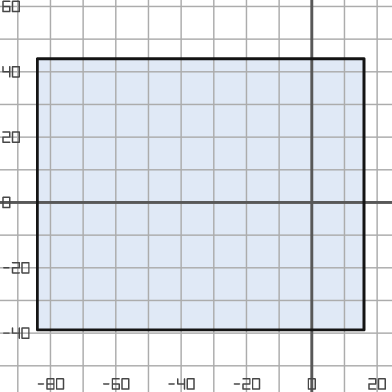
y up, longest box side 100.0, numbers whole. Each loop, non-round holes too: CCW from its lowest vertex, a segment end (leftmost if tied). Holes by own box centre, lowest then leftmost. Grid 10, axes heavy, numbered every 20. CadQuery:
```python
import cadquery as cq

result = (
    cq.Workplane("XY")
    .moveTo(-84.0, -39.0)
    .lineTo(16.0, -39.0)
    .lineTo(16.0, 44.0)
    .lineTo(-84.0, 44.0)
    .close()
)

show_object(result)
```